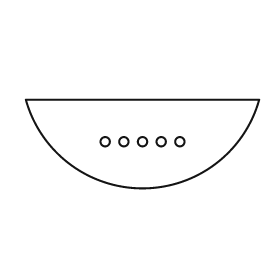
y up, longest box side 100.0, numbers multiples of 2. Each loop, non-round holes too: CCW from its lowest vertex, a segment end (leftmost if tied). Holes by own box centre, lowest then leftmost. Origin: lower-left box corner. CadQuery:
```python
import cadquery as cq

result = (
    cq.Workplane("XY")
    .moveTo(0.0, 38.0)
    .threePointArc((50.0, 0.0), (100.0, 38.0))
    .close()
    .moveTo(34.0, 20.0)
    .circle(2.0)
    .moveTo(42.0, 20.0)
    .circle(2.0)
    .moveTo(50.0, 20.0)
    .circle(2.0)
    .moveTo(58.0, 20.0)
    .circle(2.0)
    .moveTo(66.0, 20.0)
    .circle(2.0)
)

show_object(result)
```